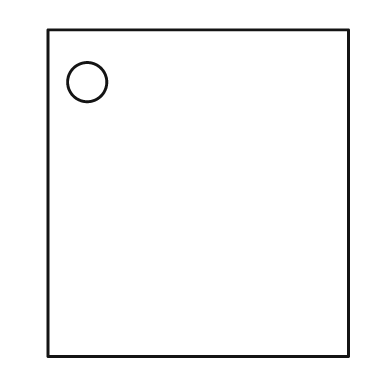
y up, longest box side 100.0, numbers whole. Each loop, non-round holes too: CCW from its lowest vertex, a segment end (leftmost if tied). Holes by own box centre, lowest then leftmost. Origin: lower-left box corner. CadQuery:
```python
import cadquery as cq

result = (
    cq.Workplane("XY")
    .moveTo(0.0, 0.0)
    .lineTo(92.0, 0.0)
    .lineTo(92.0, 100.0)
    .lineTo(0.0, 100.0)
    .close()
    .moveTo(12.0, 84.0)
    .circle(6.0)
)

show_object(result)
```